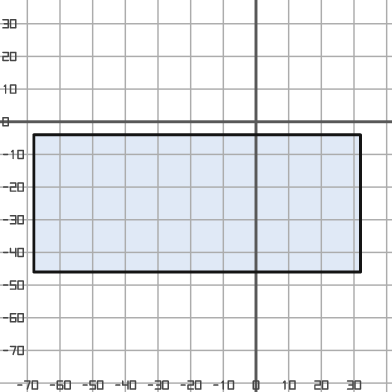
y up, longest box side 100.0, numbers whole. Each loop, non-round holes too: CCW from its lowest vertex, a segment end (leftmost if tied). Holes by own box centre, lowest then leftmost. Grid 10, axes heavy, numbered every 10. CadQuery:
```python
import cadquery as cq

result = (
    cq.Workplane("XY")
    .moveTo(-68.0, -46.0)
    .lineTo(32.0, -46.0)
    .lineTo(32.0, -4.0)
    .lineTo(-68.0, -4.0)
    .close()
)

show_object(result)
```